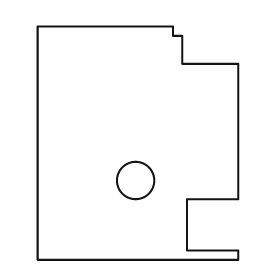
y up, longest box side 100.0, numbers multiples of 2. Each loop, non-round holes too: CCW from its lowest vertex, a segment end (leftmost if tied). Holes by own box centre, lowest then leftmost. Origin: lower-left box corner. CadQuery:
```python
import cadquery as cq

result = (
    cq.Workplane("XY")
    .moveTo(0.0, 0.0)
    .lineTo(86.0, 0.0)
    .lineTo(86.0, 4.0)
    .lineTo(64.0, 4.0)
    .lineTo(64.0, 26.0)
    .lineTo(86.0, 26.0)
    .lineTo(86.0, 84.0)
    .lineTo(62.0, 84.0)
    .lineTo(62.0, 96.0)
    .lineTo(58.0, 96.0)
    .lineTo(58.0, 100.0)
    .lineTo(0.0, 100.0)
    .close()
    .moveTo(42.0, 34.0)
    .circle(8.0)
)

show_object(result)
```